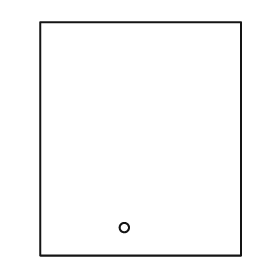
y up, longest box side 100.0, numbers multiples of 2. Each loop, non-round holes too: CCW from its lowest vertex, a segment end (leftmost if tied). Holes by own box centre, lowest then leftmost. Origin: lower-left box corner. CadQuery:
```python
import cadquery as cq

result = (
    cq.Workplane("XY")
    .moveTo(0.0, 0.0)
    .lineTo(86.0, 0.0)
    .lineTo(86.0, 100.0)
    .lineTo(0.0, 100.0)
    .close()
    .moveTo(36.0, 12.0)
    .circle(2.0)
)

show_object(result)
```